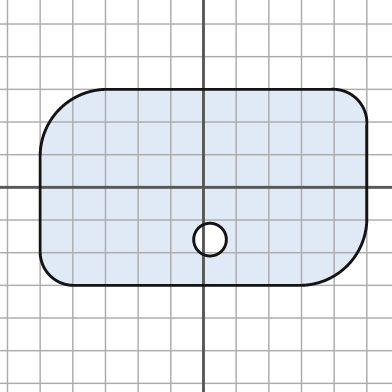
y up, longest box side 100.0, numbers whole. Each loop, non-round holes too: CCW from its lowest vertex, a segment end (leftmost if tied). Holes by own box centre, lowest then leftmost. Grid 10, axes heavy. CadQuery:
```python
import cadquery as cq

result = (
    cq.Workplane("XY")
    .moveTo(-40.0, -30.0)
    .lineTo(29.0, -30.0)
    .threePointArc((44.0, -24.0), (50.0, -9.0))
    .lineTo(50.0, 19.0)
    .threePointArc((47.0, 27.0), (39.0, 30.0))
    .lineTo(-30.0, 30.0)
    .threePointArc((-44.0, 24.0), (-50.0, 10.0))
    .lineTo(-50.0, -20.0)
    .threePointArc((-47.0, -27.0), (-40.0, -30.0))
    .close()
    .moveTo(2.0, -16.0)
    .circle(5.0)
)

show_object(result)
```